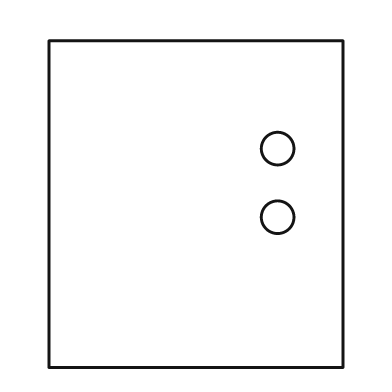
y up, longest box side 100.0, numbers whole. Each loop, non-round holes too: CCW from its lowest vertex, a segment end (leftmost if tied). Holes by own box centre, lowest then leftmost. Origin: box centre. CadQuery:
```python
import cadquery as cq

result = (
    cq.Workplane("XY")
    .moveTo(-45.0, -50.0)
    .lineTo(45.0, -50.0)
    .lineTo(45.0, 50.0)
    .lineTo(-45.0, 50.0)
    .close()
    .moveTo(25.0, -4.0)
    .circle(5.0)
    .moveTo(25.0, 17.0)
    .circle(5.0)
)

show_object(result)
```